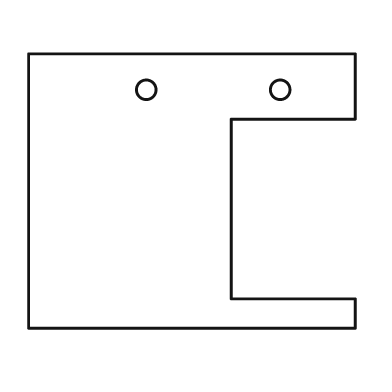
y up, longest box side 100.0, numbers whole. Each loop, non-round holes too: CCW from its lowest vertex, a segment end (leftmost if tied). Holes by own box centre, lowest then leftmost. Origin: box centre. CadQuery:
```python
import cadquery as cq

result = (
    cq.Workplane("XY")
    .moveTo(-50.0, -42.0)
    .lineTo(50.0, -42.0)
    .lineTo(50.0, -33.0)
    .lineTo(12.0, -33.0)
    .lineTo(12.0, 22.0)
    .lineTo(50.0, 22.0)
    .lineTo(50.0, 42.0)
    .lineTo(-50.0, 42.0)
    .close()
    .moveTo(-14.0, 31.0)
    .circle(3.0)
    .moveTo(27.0, 31.0)
    .circle(3.0)
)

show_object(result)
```